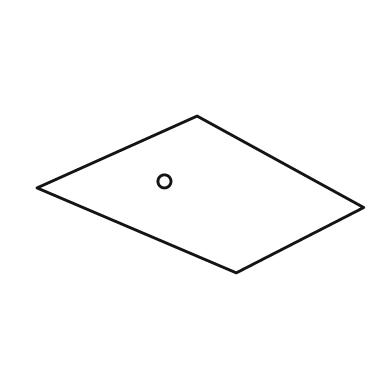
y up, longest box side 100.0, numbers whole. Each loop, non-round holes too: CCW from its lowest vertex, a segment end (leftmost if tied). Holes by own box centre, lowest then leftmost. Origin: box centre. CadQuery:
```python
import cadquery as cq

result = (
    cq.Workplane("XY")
    .moveTo(11.0, -24.0)
    .lineTo(50.0, -4.0)
    .lineTo(-1.0, 24.0)
    .lineTo(-50.0, 2.0)
    .close()
    .moveTo(-11.0, 4.0)
    .circle(2.0)
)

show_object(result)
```